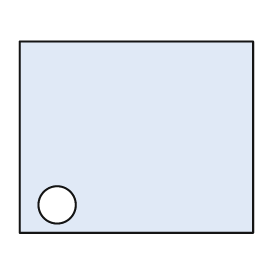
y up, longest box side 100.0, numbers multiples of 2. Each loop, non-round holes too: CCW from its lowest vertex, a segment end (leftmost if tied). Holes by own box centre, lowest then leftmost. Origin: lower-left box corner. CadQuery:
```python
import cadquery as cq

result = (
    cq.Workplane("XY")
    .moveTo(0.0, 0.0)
    .lineTo(100.0, 0.0)
    .lineTo(100.0, 82.0)
    .lineTo(0.0, 82.0)
    .close()
    .moveTo(16.0, 12.0)
    .circle(8.0)
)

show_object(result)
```